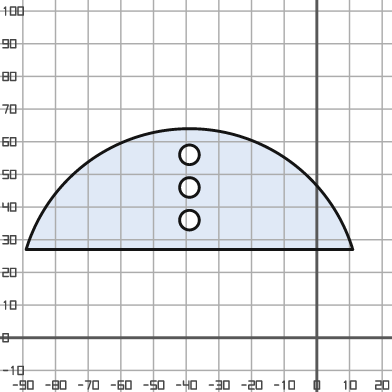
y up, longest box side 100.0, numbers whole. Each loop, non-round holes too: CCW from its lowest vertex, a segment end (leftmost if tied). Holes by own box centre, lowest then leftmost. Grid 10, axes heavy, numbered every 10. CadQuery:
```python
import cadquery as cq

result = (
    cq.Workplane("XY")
    .moveTo(-89.0, 27.0)
    .lineTo(11.0, 27.0)
    .threePointArc((-39.0, 64.0), (-89.0, 27.0))
    .close()
    .moveTo(-39.0, 36.0)
    .circle(3.0)
    .moveTo(-39.0, 46.0)
    .circle(3.0)
    .moveTo(-39.0, 56.0)
    .circle(3.0)
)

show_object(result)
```